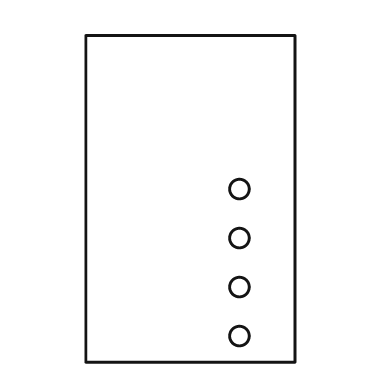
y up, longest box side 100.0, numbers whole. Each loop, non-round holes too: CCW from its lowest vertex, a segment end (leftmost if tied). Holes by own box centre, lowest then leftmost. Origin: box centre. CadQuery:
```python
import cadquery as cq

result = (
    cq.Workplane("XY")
    .moveTo(-32.0, -50.0)
    .lineTo(32.0, -50.0)
    .lineTo(32.0, 50.0)
    .lineTo(-32.0, 50.0)
    .close()
    .moveTo(15.0, -42.0)
    .circle(3.0)
    .moveTo(15.0, -27.0)
    .circle(3.0)
    .moveTo(15.0, -12.0)
    .circle(3.0)
    .moveTo(15.0, 3.0)
    .circle(3.0)
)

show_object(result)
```